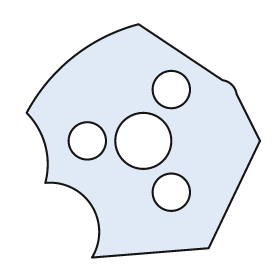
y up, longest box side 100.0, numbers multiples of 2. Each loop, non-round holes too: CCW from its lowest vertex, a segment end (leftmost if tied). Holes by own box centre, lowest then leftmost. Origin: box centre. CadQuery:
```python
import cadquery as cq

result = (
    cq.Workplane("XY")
    .moveTo(-22.0, -50.0)
    .lineTo(28.0, -46.0)
    .lineTo(50.0, 0.0)
    .lineTo(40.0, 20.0)
    .threePointArc((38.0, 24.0), (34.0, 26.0))
    .lineTo(-2.0, 50.0)
    .threePointArc((-30.0, 36.0), (-50.0, 12.0))
    .threePointArc((-42.0, -2.0), (-42.0, -18.0))
    .threePointArc((-22.0, -28.0), (-22.0, -50.0))
    .close()
    .moveTo(12.0, -22.0)
    .circle(8.0)
    .moveTo(-24.0, 0.0)
    .circle(8.0)
    .moveTo(0.0, 0.0)
    .circle(12.0)
    .moveTo(12.0, 22.0)
    .circle(8.0)
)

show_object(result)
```